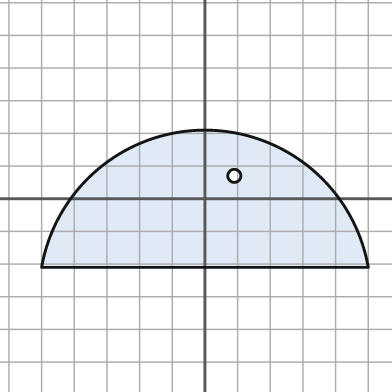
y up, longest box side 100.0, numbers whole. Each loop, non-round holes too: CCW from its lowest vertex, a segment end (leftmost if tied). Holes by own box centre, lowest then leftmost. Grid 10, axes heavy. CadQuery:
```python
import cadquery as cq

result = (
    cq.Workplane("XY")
    .moveTo(-50.0, -21.0)
    .lineTo(50.0, -21.0)
    .threePointArc((0.0, 21.0), (-50.0, -21.0))
    .close()
    .moveTo(9.0, 7.0)
    .circle(2.0)
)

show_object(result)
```